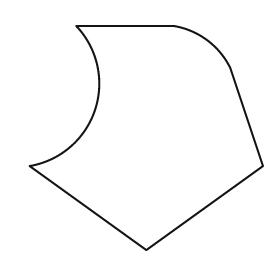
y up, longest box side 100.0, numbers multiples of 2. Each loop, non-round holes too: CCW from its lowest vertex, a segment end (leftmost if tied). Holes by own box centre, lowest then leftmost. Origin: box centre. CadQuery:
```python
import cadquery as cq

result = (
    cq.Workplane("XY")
    .moveTo(0.0, -48.0)
    .lineTo(50.0, -12.0)
    .lineTo(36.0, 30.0)
    .threePointArc((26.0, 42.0), (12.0, 48.0))
    .lineTo(-30.0, 48.0)
    .threePointArc((-22.0, 12.0), (-50.0, -12.0))
    .close()
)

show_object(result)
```